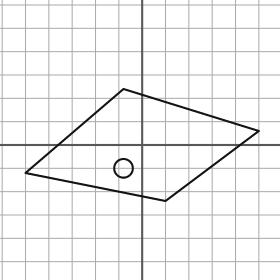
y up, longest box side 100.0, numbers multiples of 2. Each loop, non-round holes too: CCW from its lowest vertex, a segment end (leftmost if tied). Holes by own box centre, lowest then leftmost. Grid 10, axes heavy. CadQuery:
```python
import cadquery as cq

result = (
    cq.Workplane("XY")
    .moveTo(10.0, -24.0)
    .lineTo(50.0, 6.0)
    .lineTo(-8.0, 24.0)
    .lineTo(-50.0, -12.0)
    .close()
    .moveTo(-8.0, -10.0)
    .circle(4.0)
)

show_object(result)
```